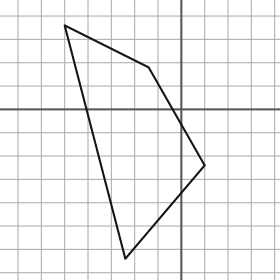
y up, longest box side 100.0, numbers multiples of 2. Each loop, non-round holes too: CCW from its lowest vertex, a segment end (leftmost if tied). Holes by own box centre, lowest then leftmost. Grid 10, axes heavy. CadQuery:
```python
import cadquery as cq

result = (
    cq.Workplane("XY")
    .moveTo(-24.0, -64.0)
    .lineTo(10.0, -24.0)
    .lineTo(-14.0, 18.0)
    .lineTo(-50.0, 36.0)
    .close()
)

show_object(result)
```